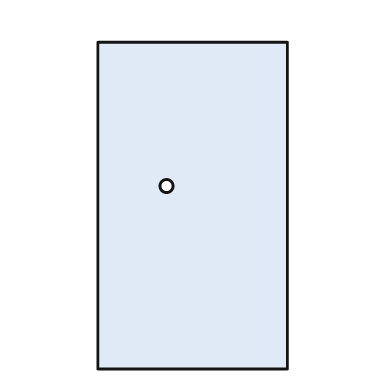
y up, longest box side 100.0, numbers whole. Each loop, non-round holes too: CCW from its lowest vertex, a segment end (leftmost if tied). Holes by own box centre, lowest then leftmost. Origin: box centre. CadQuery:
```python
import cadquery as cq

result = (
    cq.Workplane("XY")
    .moveTo(-29.0, -50.0)
    .lineTo(29.0, -50.0)
    .lineTo(29.0, 50.0)
    .lineTo(-29.0, 50.0)
    .close()
    .moveTo(-8.0, 6.0)
    .circle(2.0)
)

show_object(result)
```